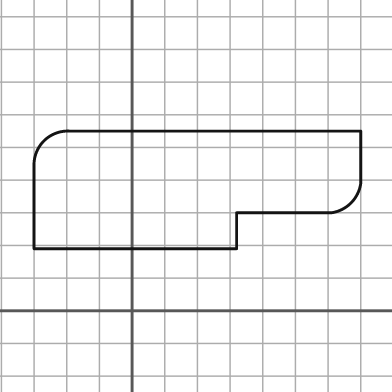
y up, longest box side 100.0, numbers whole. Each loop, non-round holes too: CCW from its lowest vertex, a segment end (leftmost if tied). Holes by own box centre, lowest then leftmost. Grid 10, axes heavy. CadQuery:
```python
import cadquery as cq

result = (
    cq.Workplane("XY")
    .moveTo(-30.0, 19.0)
    .lineTo(32.0, 19.0)
    .lineTo(32.0, 30.0)
    .lineTo(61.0, 30.0)
    .threePointArc((67.0, 33.0), (70.0, 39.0))
    .lineTo(70.0, 55.0)
    .lineTo(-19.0, 55.0)
    .threePointArc((-27.0, 52.0), (-30.0, 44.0))
    .close()
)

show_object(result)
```